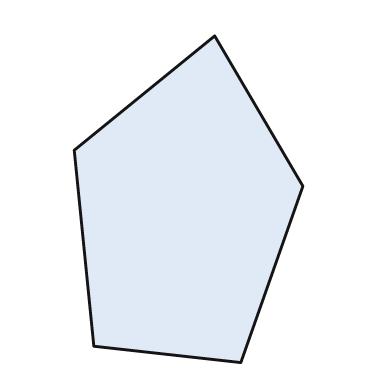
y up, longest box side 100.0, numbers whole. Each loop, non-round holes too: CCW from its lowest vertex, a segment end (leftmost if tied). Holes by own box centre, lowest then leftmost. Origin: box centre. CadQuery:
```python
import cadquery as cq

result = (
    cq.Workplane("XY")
    .moveTo(16.0, -50.0)
    .lineTo(35.0, 4.0)
    .lineTo(8.0, 50.0)
    .lineTo(-35.0, 15.0)
    .lineTo(-29.0, -45.0)
    .close()
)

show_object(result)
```